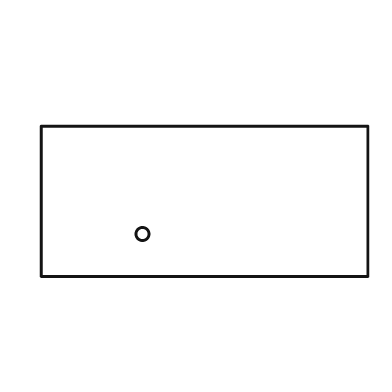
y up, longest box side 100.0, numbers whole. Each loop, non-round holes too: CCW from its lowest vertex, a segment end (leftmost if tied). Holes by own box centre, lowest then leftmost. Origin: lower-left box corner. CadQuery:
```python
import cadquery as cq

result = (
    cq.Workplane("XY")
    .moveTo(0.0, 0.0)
    .lineTo(100.0, 0.0)
    .lineTo(100.0, 46.0)
    .lineTo(0.0, 46.0)
    .close()
    .moveTo(31.0, 13.0)
    .circle(2.0)
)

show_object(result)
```